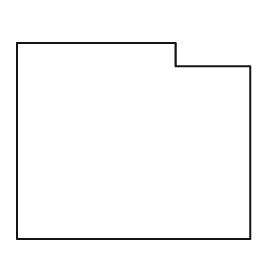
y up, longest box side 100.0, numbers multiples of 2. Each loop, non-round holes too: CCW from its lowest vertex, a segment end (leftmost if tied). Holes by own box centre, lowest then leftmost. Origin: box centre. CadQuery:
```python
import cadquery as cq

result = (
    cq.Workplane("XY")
    .moveTo(-50.0, -42.0)
    .lineTo(50.0, -42.0)
    .lineTo(50.0, 32.0)
    .lineTo(18.0, 32.0)
    .lineTo(18.0, 42.0)
    .lineTo(-50.0, 42.0)
    .close()
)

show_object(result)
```